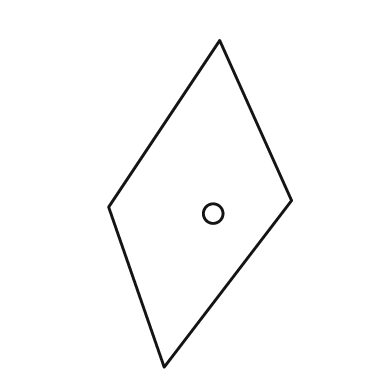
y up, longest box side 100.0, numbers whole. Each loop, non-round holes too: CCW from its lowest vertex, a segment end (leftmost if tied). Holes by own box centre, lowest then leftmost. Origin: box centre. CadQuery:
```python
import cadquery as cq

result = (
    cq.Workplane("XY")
    .moveTo(-11.0, -50.0)
    .lineTo(28.0, 1.0)
    .lineTo(6.0, 50.0)
    .lineTo(-28.0, -1.0)
    .close()
    .moveTo(4.0, -3.0)
    .circle(3.0)
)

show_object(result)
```